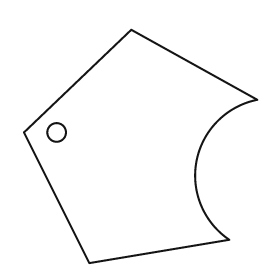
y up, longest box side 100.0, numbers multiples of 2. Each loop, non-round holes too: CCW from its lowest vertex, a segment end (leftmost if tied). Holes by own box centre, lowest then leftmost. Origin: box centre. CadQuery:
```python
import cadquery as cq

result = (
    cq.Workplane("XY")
    .moveTo(-22.0, -50.0)
    .lineTo(38.0, -40.0)
    .threePointArc((24.0, -6.0), (50.0, 20.0))
    .lineTo(-4.0, 50.0)
    .lineTo(-50.0, 6.0)
    .close()
    .moveTo(-36.0, 6.0)
    .circle(4.0)
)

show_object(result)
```